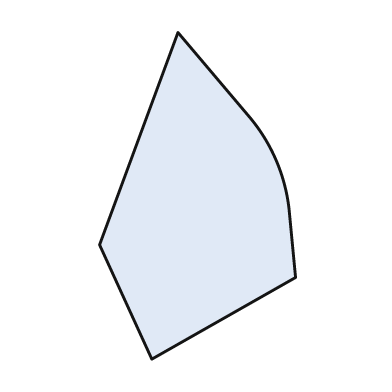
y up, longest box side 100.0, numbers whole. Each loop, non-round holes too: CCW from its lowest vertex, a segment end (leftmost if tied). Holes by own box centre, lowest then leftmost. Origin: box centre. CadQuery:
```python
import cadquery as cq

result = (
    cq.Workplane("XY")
    .moveTo(-14.0, -50.0)
    .lineTo(30.0, -25.0)
    .lineTo(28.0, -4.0)
    .threePointArc((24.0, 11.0), (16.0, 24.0))
    .lineTo(-6.0, 50.0)
    .lineTo(-30.0, -15.0)
    .close()
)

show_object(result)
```